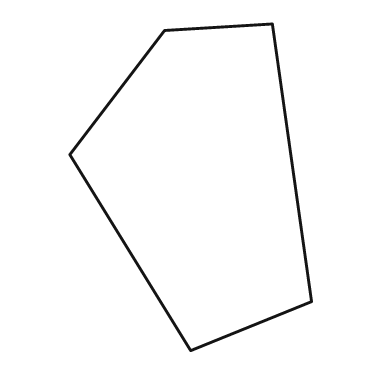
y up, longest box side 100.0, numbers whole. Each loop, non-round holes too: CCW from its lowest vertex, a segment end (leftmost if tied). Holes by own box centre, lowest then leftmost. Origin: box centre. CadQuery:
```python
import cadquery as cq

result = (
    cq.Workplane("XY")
    .moveTo(0.0, -50.0)
    .lineTo(37.0, -35.0)
    .lineTo(25.0, 50.0)
    .lineTo(-8.0, 48.0)
    .lineTo(-37.0, 10.0)
    .close()
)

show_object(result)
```